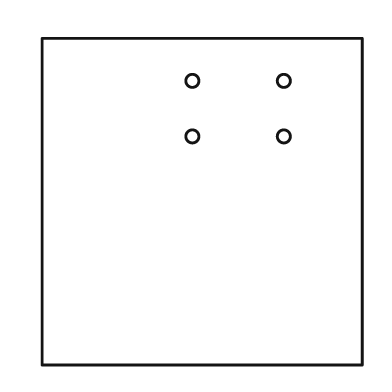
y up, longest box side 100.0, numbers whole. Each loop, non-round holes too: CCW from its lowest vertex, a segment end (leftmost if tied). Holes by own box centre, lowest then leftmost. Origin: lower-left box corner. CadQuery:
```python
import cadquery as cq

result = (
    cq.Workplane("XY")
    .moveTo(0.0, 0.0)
    .lineTo(98.0, 0.0)
    .lineTo(98.0, 100.0)
    .lineTo(0.0, 100.0)
    .close()
    .moveTo(46.0, 70.0)
    .circle(2.0)
    .moveTo(74.0, 70.0)
    .circle(2.0)
    .moveTo(46.0, 87.0)
    .circle(2.0)
    .moveTo(74.0, 87.0)
    .circle(2.0)
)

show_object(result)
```